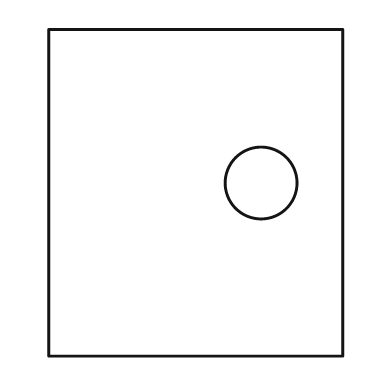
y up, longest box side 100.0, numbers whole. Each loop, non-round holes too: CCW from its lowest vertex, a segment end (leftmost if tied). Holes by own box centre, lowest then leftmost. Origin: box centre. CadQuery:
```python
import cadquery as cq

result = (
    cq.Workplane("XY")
    .moveTo(-45.0, -50.0)
    .lineTo(45.0, -50.0)
    .lineTo(45.0, 50.0)
    .lineTo(-45.0, 50.0)
    .close()
    .moveTo(20.0, 3.0)
    .circle(11.0)
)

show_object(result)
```